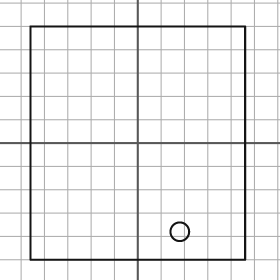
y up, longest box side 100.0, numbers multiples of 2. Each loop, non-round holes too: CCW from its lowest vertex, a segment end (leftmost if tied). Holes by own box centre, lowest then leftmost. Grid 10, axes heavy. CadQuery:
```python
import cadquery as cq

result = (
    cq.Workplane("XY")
    .moveTo(-46.0, -50.0)
    .lineTo(46.0, -50.0)
    .lineTo(46.0, 50.0)
    .lineTo(-46.0, 50.0)
    .close()
    .moveTo(18.0, -38.0)
    .circle(4.0)
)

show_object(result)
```